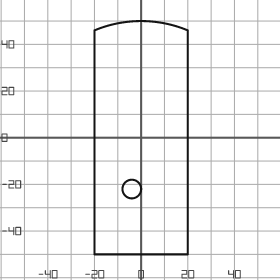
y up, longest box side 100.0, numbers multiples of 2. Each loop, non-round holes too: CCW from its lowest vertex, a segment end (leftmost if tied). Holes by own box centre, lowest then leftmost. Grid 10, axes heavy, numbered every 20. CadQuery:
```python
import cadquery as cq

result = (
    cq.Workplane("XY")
    .moveTo(-20.0, -50.0)
    .lineTo(20.0, -50.0)
    .lineTo(20.0, 46.0)
    .threePointArc((0.0, 50.0), (-20.0, 46.0))
    .close()
    .moveTo(-4.0, -22.0)
    .circle(4.0)
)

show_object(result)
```